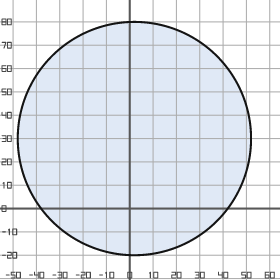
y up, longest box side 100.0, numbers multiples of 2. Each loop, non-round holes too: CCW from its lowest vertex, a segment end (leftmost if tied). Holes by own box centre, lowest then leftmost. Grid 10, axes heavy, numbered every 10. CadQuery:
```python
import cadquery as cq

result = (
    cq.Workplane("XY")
    .moveTo(2.0, 30.0)
    .circle(50.0)
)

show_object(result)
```